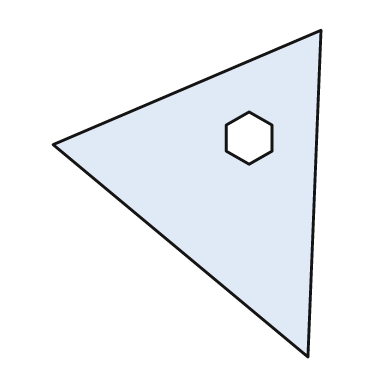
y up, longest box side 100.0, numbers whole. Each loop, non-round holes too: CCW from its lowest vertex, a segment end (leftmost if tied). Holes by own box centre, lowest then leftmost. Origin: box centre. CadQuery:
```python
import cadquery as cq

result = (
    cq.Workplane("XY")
    .moveTo(37.0, -50.0)
    .lineTo(41.0, 50.0)
    .lineTo(-41.0, 15.0)
    .close()
    .moveTo(19.0, 9.0)
    .lineTo(26.0, 13.0)
    .lineTo(26.0, 21.0)
    .lineTo(19.0, 25.0)
    .lineTo(12.0, 21.0)
    .lineTo(12.0, 13.0)
    .close()
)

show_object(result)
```